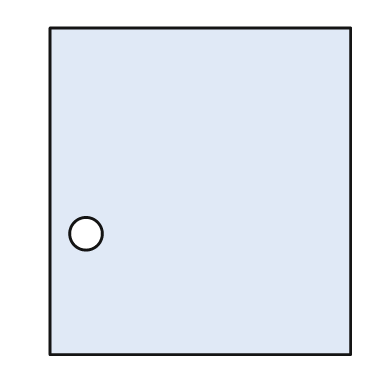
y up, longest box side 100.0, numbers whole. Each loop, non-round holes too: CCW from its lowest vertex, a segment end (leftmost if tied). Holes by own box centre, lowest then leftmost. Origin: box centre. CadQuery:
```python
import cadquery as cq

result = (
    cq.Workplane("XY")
    .moveTo(-46.0, -50.0)
    .lineTo(46.0, -50.0)
    .lineTo(46.0, 50.0)
    .lineTo(-46.0, 50.0)
    .close()
    .moveTo(-35.0, -13.0)
    .circle(5.0)
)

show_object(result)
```